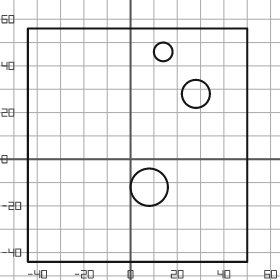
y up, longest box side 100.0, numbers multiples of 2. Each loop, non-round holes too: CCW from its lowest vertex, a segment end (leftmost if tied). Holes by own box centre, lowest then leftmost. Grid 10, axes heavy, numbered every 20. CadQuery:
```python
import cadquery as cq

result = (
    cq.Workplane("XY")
    .moveTo(-44.0, -44.0)
    .lineTo(50.0, -44.0)
    .lineTo(50.0, 56.0)
    .lineTo(-44.0, 56.0)
    .close()
    .moveTo(8.0, -12.0)
    .circle(8.0)
    .moveTo(28.0, 28.0)
    .circle(6.0)
    .moveTo(14.0, 46.0)
    .circle(4.0)
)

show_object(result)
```